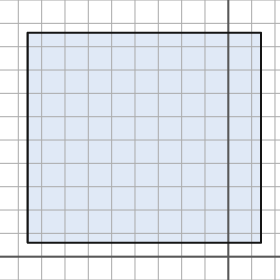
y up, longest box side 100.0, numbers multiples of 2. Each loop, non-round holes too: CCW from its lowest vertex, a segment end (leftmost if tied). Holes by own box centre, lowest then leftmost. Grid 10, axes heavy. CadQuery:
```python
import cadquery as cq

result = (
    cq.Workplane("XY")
    .moveTo(-86.0, 6.0)
    .lineTo(14.0, 6.0)
    .lineTo(14.0, 96.0)
    .lineTo(-86.0, 96.0)
    .close()
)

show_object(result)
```